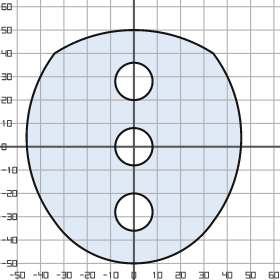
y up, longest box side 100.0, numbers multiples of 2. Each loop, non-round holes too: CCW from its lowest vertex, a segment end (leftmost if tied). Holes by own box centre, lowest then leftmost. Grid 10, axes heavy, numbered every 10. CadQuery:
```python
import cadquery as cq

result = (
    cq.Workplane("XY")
    .moveTo(-34.0, -32.0)
    .threePointArc((0.0, -50.0), (34.0, -32.0))
    .threePointArc((46.0, 4.0), (34.0, 40.0))
    .threePointArc((0.0, 50.0), (-34.0, 40.0))
    .threePointArc((-46.0, 4.0), (-34.0, -32.0))
    .close()
    .moveTo(0.0, -28.0)
    .circle(8.0)
    .moveTo(0.0, 0.0)
    .circle(8.0)
    .moveTo(0.0, 28.0)
    .circle(8.0)
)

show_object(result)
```